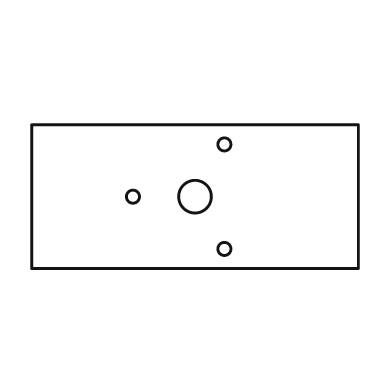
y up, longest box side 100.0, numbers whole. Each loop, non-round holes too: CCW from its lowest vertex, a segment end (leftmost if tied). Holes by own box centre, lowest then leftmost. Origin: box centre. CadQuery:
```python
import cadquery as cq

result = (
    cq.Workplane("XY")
    .moveTo(-50.0, -22.0)
    .lineTo(50.0, -22.0)
    .lineTo(50.0, 22.0)
    .lineTo(-50.0, 22.0)
    .close()
    .moveTo(9.0, -16.0)
    .circle(2.0)
    .moveTo(-19.0, 0.0)
    .circle(2.0)
    .moveTo(0.0, 0.0)
    .circle(5.0)
    .moveTo(9.0, 16.0)
    .circle(2.0)
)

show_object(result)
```